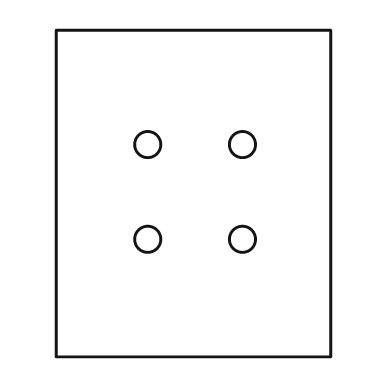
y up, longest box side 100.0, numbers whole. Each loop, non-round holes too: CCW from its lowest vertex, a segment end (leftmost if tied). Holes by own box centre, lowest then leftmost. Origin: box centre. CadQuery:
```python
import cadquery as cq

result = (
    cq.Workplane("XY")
    .moveTo(-42.0, -50.0)
    .lineTo(42.0, -50.0)
    .lineTo(42.0, 50.0)
    .lineTo(-42.0, 50.0)
    .close()
    .moveTo(-14.0, -14.0)
    .circle(4.0)
    .moveTo(15.0, -14.0)
    .circle(4.0)
    .moveTo(-14.0, 15.0)
    .circle(4.0)
    .moveTo(15.0, 15.0)
    .circle(4.0)
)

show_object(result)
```